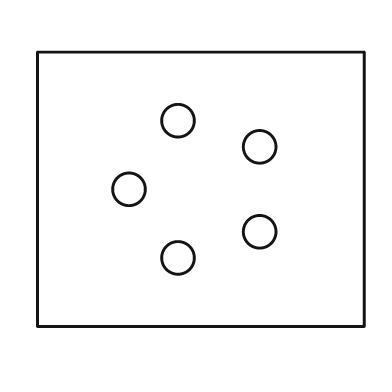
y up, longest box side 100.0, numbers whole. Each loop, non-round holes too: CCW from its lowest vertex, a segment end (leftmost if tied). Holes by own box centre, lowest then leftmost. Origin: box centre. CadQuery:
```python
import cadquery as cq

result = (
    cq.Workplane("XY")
    .moveTo(-50.0, -42.0)
    .lineTo(50.0, -42.0)
    .lineTo(50.0, 42.0)
    .lineTo(-50.0, 42.0)
    .close()
    .moveTo(-7.0, -21.0)
    .circle(5.0)
    .moveTo(18.0, -13.0)
    .circle(5.0)
    .moveTo(-22.0, 0.0)
    .circle(5.0)
    .moveTo(18.0, 13.0)
    .circle(5.0)
    .moveTo(-7.0, 21.0)
    .circle(5.0)
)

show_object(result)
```